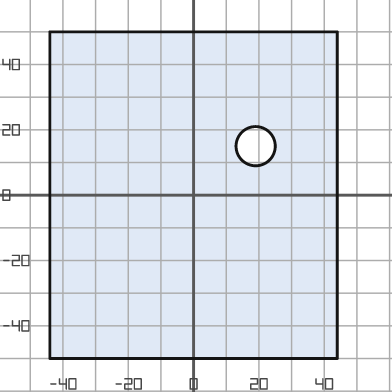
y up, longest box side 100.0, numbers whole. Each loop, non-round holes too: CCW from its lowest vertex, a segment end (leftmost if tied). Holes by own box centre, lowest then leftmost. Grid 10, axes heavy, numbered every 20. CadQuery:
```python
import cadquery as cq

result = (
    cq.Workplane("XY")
    .moveTo(-44.0, -50.0)
    .lineTo(44.0, -50.0)
    .lineTo(44.0, 50.0)
    .lineTo(-44.0, 50.0)
    .close()
    .moveTo(19.0, 15.0)
    .circle(6.0)
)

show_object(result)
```